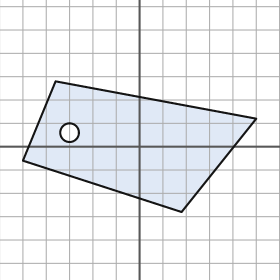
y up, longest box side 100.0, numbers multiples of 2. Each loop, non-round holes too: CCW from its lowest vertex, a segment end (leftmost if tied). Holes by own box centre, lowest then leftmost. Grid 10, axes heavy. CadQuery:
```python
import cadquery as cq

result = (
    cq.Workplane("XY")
    .moveTo(18.0, -28.0)
    .lineTo(50.0, 12.0)
    .lineTo(-36.0, 28.0)
    .lineTo(-50.0, -6.0)
    .close()
    .moveTo(-30.0, 6.0)
    .circle(4.0)
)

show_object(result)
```